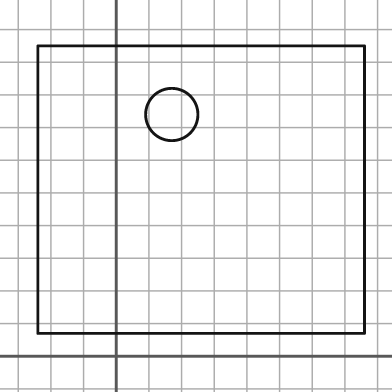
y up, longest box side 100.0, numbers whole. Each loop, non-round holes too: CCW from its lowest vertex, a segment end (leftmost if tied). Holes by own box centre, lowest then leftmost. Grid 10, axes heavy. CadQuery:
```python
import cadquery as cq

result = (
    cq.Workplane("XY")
    .moveTo(-24.0, 7.0)
    .lineTo(76.0, 7.0)
    .lineTo(76.0, 95.0)
    .lineTo(-24.0, 95.0)
    .close()
    .moveTo(17.0, 74.0)
    .circle(8.0)
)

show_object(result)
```